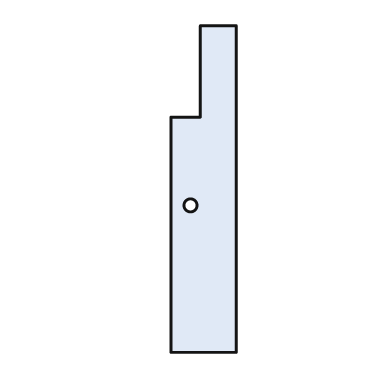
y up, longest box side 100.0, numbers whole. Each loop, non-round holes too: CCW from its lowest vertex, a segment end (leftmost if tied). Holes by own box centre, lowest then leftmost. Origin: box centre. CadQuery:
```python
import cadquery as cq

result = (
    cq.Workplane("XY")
    .moveTo(-10.0, -50.0)
    .lineTo(10.0, -50.0)
    .lineTo(10.0, 50.0)
    .lineTo(-1.0, 50.0)
    .lineTo(-1.0, 22.0)
    .lineTo(-10.0, 22.0)
    .close()
    .moveTo(-4.0, -5.0)
    .circle(2.0)
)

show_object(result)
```